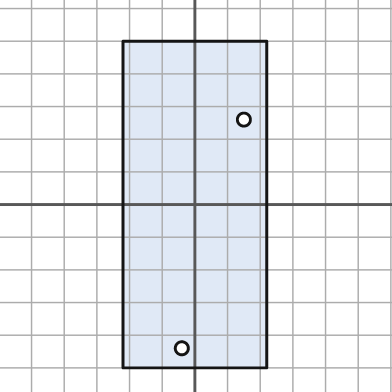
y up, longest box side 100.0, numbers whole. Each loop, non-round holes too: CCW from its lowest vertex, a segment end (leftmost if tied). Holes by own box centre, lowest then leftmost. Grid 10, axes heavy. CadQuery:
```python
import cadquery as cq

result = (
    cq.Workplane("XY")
    .moveTo(-22.0, -50.0)
    .lineTo(22.0, -50.0)
    .lineTo(22.0, 50.0)
    .lineTo(-22.0, 50.0)
    .close()
    .moveTo(-4.0, -44.0)
    .circle(2.0)
    .moveTo(15.0, 26.0)
    .circle(2.0)
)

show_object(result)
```